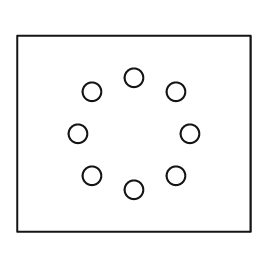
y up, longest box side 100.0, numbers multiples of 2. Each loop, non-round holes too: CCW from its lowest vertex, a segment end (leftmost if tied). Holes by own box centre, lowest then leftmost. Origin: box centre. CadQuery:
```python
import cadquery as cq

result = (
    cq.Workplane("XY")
    .moveTo(-50.0, -42.0)
    .lineTo(50.0, -42.0)
    .lineTo(50.0, 42.0)
    .lineTo(-50.0, 42.0)
    .close()
    .moveTo(0.0, -24.0)
    .circle(4.0)
    .moveTo(-18.0, -18.0)
    .circle(4.0)
    .moveTo(18.0, -18.0)
    .circle(4.0)
    .moveTo(-24.0, 0.0)
    .circle(4.0)
    .moveTo(24.0, 0.0)
    .circle(4.0)
    .moveTo(-18.0, 18.0)
    .circle(4.0)
    .moveTo(18.0, 18.0)
    .circle(4.0)
    .moveTo(0.0, 24.0)
    .circle(4.0)
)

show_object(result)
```